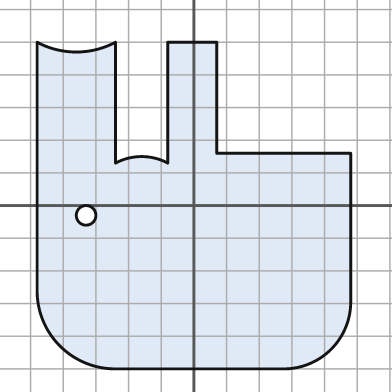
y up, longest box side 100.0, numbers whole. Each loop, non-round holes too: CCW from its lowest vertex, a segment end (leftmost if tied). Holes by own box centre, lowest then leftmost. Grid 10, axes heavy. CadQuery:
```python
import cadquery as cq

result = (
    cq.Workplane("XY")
    .moveTo(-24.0, -50.0)
    .lineTo(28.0, -50.0)
    .threePointArc((42.0, -44.0), (48.0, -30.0))
    .lineTo(48.0, 16.0)
    .lineTo(7.0, 16.0)
    .lineTo(7.0, 50.0)
    .lineTo(-8.0, 50.0)
    .lineTo(-8.0, 13.0)
    .threePointArc((-16.0, 15.0), (-24.0, 13.0))
    .lineTo(-24.0, 50.0)
    .threePointArc((-36.0, 47.0), (-48.0, 50.0))
    .lineTo(-48.0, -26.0)
    .threePointArc((-41.0, -43.0), (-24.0, -50.0))
    .close()
    .moveTo(-33.0, -3.0)
    .circle(3.0)
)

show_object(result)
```